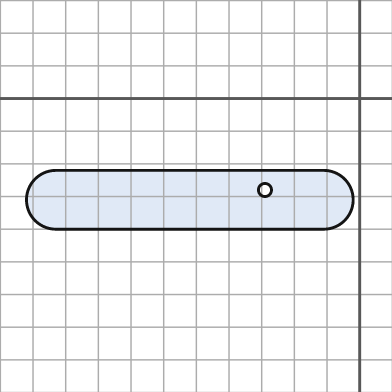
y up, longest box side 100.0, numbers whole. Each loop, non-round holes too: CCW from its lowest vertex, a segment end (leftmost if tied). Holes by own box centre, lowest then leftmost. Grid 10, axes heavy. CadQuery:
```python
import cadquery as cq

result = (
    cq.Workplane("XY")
    .moveTo(-93.0, -40.0)
    .lineTo(-11.0, -40.0)
    .threePointArc((-2.0, -31.0), (-11.0, -22.0))
    .lineTo(-93.0, -22.0)
    .threePointArc((-102.0, -31.0), (-93.0, -40.0))
    .close()
    .moveTo(-29.0, -28.0)
    .circle(2.0)
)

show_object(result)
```